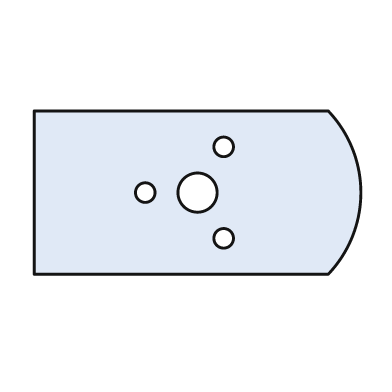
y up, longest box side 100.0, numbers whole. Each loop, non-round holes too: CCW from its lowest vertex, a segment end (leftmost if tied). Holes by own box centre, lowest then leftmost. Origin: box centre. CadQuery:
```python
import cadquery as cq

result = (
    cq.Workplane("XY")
    .moveTo(-50.0, -25.0)
    .lineTo(40.0, -25.0)
    .threePointArc((50.0, 0.0), (40.0, 25.0))
    .lineTo(-50.0, 25.0)
    .close()
    .moveTo(8.0, -14.0)
    .circle(3.0)
    .moveTo(-16.0, 0.0)
    .circle(3.0)
    .moveTo(0.0, 0.0)
    .circle(6.0)
    .moveTo(8.0, 14.0)
    .circle(3.0)
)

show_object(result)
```